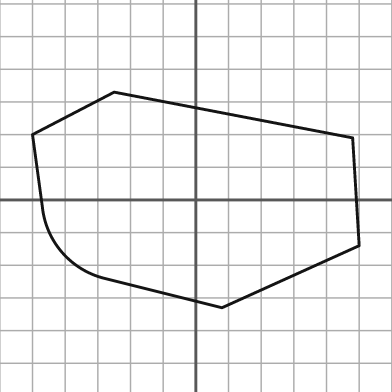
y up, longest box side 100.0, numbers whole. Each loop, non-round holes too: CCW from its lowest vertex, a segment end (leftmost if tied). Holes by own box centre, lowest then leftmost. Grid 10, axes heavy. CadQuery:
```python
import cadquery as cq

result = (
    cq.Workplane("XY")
    .moveTo(8.0, -33.0)
    .lineTo(50.0, -14.0)
    .lineTo(48.0, 19.0)
    .lineTo(-25.0, 33.0)
    .lineTo(-50.0, 20.0)
    .lineTo(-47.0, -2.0)
    .threePointArc((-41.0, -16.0), (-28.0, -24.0))
    .close()
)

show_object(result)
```